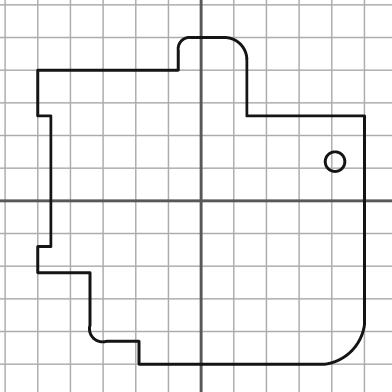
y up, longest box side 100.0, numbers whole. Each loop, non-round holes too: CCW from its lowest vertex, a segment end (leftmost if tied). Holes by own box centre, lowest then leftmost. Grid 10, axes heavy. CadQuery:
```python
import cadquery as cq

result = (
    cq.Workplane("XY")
    .moveTo(-19.0, -50.0)
    .lineTo(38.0, -50.0)
    .threePointArc((46.0, -46.0), (50.0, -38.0))
    .lineTo(50.0, 26.0)
    .lineTo(14.0, 26.0)
    .lineTo(14.0, 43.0)
    .threePointArc((12.0, 48.0), (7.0, 50.0))
    .lineTo(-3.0, 50.0)
    .threePointArc((-6.0, 49.0), (-7.0, 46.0))
    .lineTo(-7.0, 40.0)
    .lineTo(-50.0, 40.0)
    .lineTo(-50.0, 26.0)
    .lineTo(-46.0, 26.0)
    .lineTo(-46.0, -14.0)
    .lineTo(-50.0, -14.0)
    .lineTo(-50.0, -22.0)
    .lineTo(-34.0, -22.0)
    .lineTo(-34.0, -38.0)
    .threePointArc((-33.0, -42.0), (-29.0, -43.0))
    .lineTo(-19.0, -43.0)
    .close()
    .moveTo(41.0, 12.0)
    .circle(3.0)
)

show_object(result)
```